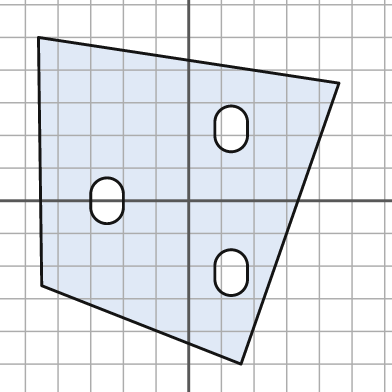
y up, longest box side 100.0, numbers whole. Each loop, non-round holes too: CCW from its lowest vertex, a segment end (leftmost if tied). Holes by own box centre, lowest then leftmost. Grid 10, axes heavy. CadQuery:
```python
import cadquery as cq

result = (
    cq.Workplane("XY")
    .moveTo(16.0, -50.0)
    .lineTo(46.0, 36.0)
    .lineTo(-46.0, 50.0)
    .lineTo(-45.0, -26.0)
    .close()
    .moveTo(8.0, -24.0)
    .threePointArc((13.0, -29.0), (18.0, -24.0))
    .lineTo(18.0, -20.0)
    .threePointArc((13.0, -15.0), (8.0, -20.0))
    .close()
    .moveTo(-30.0, -2.0)
    .threePointArc((-25.0, -7.0), (-20.0, -2.0))
    .lineTo(-20.0, 2.0)
    .threePointArc((-25.0, 7.0), (-30.0, 2.0))
    .close()
    .moveTo(8.0, 20.0)
    .threePointArc((13.0, 15.0), (18.0, 20.0))
    .lineTo(18.0, 24.0)
    .threePointArc((13.0, 29.0), (8.0, 24.0))
    .close()
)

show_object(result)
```